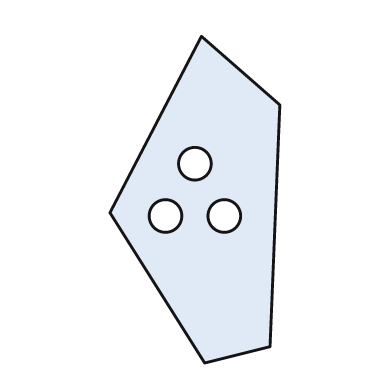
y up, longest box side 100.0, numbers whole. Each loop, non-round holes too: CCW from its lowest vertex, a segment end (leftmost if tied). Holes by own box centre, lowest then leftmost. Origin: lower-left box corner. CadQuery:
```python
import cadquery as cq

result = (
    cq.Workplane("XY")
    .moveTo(29.0, 0.0)
    .lineTo(49.0, 5.0)
    .lineTo(52.0, 79.0)
    .lineTo(28.0, 100.0)
    .lineTo(0.0, 46.0)
    .close()
    .moveTo(17.0, 45.0)
    .circle(5.0)
    .moveTo(35.0, 45.0)
    .circle(5.0)
    .moveTo(26.0, 61.0)
    .circle(5.0)
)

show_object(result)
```